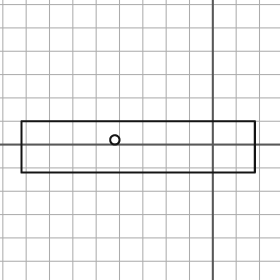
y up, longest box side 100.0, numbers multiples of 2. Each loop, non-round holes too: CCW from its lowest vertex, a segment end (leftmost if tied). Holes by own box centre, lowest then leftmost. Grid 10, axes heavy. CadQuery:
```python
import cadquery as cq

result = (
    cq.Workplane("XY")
    .moveTo(-82.0, -12.0)
    .lineTo(18.0, -12.0)
    .lineTo(18.0, 10.0)
    .lineTo(-82.0, 10.0)
    .close()
    .moveTo(-42.0, 2.0)
    .circle(2.0)
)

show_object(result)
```